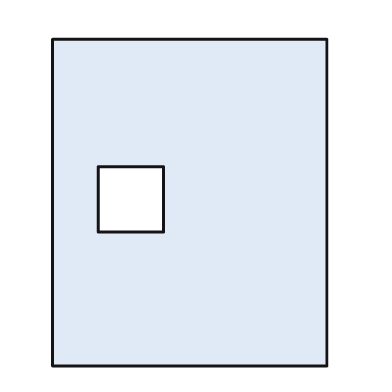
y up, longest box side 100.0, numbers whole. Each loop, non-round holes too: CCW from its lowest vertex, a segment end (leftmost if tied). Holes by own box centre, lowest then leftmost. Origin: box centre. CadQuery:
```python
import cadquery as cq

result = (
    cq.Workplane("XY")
    .moveTo(-42.0, -50.0)
    .lineTo(42.0, -50.0)
    .lineTo(42.0, 50.0)
    .lineTo(-42.0, 50.0)
    .close()
    .moveTo(-28.0, -9.0)
    .lineTo(-8.0, -9.0)
    .lineTo(-8.0, 11.0)
    .lineTo(-28.0, 11.0)
    .close()
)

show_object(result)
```